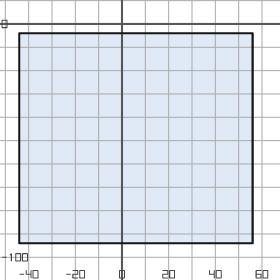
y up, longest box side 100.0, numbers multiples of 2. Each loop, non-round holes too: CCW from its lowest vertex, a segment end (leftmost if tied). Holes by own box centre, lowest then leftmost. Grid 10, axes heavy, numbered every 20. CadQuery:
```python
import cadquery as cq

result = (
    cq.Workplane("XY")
    .moveTo(-44.0, -94.0)
    .lineTo(56.0, -94.0)
    .lineTo(56.0, -4.0)
    .lineTo(-44.0, -4.0)
    .close()
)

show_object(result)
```